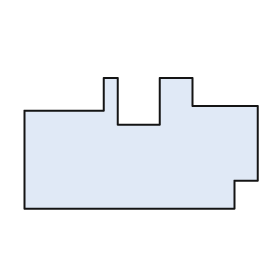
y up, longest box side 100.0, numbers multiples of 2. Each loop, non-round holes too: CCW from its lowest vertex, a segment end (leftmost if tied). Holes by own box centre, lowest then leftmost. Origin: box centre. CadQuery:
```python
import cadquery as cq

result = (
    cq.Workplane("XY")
    .moveTo(-50.0, -28.0)
    .lineTo(40.0, -28.0)
    .lineTo(40.0, -16.0)
    .lineTo(50.0, -16.0)
    .lineTo(50.0, 16.0)
    .lineTo(22.0, 16.0)
    .lineTo(22.0, 28.0)
    .lineTo(8.0, 28.0)
    .lineTo(8.0, 8.0)
    .lineTo(-10.0, 8.0)
    .lineTo(-10.0, 28.0)
    .lineTo(-16.0, 28.0)
    .lineTo(-16.0, 14.0)
    .lineTo(-50.0, 14.0)
    .close()
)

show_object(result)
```